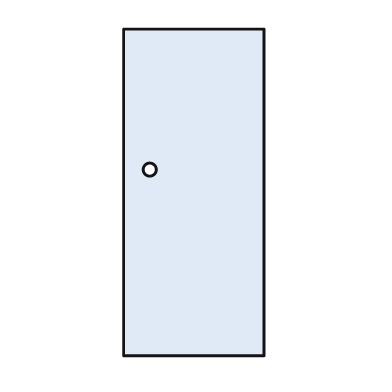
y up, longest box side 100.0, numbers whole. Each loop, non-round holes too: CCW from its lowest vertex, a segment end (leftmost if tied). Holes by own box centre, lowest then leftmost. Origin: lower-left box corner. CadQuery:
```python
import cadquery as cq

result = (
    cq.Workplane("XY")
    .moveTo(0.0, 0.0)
    .lineTo(43.0, 0.0)
    .lineTo(43.0, 100.0)
    .lineTo(0.0, 100.0)
    .close()
    .moveTo(8.0, 57.0)
    .circle(2.0)
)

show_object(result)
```